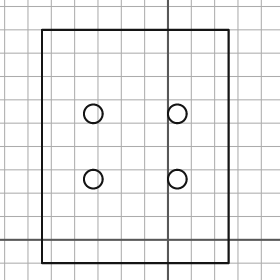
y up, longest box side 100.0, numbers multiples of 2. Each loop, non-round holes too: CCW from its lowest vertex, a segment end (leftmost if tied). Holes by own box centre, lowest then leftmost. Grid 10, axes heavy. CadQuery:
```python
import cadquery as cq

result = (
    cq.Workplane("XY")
    .moveTo(-54.0, -10.0)
    .lineTo(26.0, -10.0)
    .lineTo(26.0, 90.0)
    .lineTo(-54.0, 90.0)
    .close()
    .moveTo(-32.0, 26.0)
    .circle(4.0)
    .moveTo(4.0, 26.0)
    .circle(4.0)
    .moveTo(-32.0, 54.0)
    .circle(4.0)
    .moveTo(4.0, 54.0)
    .circle(4.0)
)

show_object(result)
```